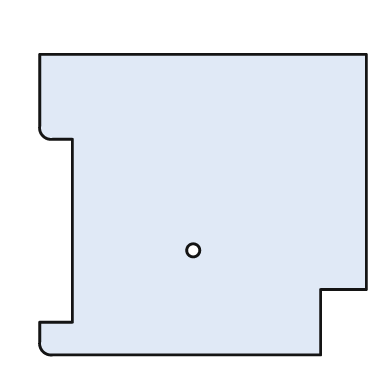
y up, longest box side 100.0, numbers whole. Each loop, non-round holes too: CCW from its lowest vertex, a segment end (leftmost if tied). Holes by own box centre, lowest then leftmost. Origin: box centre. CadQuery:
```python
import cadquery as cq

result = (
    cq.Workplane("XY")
    .moveTo(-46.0, -46.0)
    .lineTo(36.0, -46.0)
    .lineTo(36.0, -26.0)
    .lineTo(50.0, -26.0)
    .lineTo(50.0, 46.0)
    .lineTo(-50.0, 46.0)
    .lineTo(-50.0, 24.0)
    .threePointArc((-49.0, 21.0), (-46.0, 20.0))
    .lineTo(-40.0, 20.0)
    .lineTo(-40.0, -36.0)
    .lineTo(-50.0, -36.0)
    .lineTo(-50.0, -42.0)
    .threePointArc((-49.0, -45.0), (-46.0, -46.0))
    .close()
    .moveTo(-3.0, -14.0)
    .circle(2.0)
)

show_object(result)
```